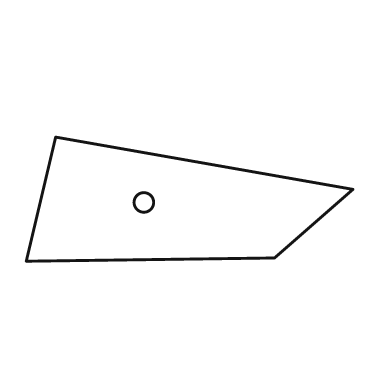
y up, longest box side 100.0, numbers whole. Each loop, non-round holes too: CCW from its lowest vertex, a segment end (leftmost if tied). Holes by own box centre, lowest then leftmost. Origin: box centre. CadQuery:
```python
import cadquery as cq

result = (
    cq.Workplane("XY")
    .moveTo(-50.0, -19.0)
    .lineTo(26.0, -18.0)
    .lineTo(50.0, 3.0)
    .lineTo(-41.0, 19.0)
    .close()
    .moveTo(-14.0, -1.0)
    .circle(3.0)
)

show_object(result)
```